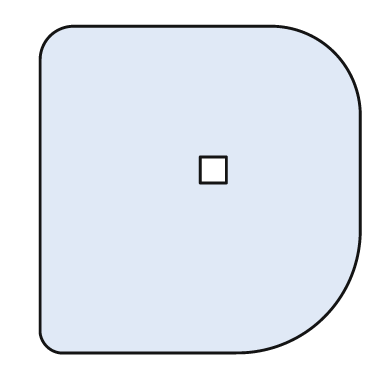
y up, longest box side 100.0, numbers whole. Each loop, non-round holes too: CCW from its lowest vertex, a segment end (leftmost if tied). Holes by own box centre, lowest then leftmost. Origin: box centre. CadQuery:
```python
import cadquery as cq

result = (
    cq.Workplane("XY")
    .moveTo(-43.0, -50.0)
    .lineTo(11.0, -50.0)
    .threePointArc((38.0, -39.0), (49.0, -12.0))
    .lineTo(49.0, 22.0)
    .threePointArc((41.0, 42.0), (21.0, 50.0))
    .lineTo(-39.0, 50.0)
    .threePointArc((-46.0, 47.0), (-49.0, 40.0))
    .lineTo(-49.0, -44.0)
    .threePointArc((-47.0, -48.0), (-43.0, -50.0))
    .close()
    .moveTo(0.0, 2.0)
    .lineTo(8.0, 2.0)
    .lineTo(8.0, 10.0)
    .lineTo(0.0, 10.0)
    .close()
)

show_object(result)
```